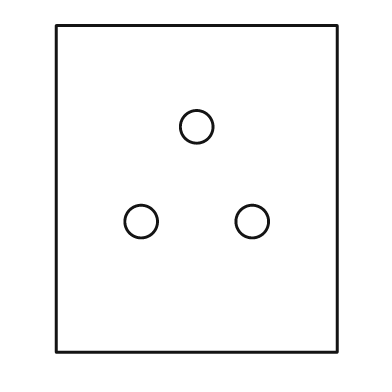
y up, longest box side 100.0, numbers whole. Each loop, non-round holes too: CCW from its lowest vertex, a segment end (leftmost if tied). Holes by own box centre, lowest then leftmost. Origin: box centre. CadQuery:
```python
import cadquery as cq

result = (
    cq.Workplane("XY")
    .moveTo(-43.0, -50.0)
    .lineTo(43.0, -50.0)
    .lineTo(43.0, 50.0)
    .lineTo(-43.0, 50.0)
    .close()
    .moveTo(-17.0, -10.0)
    .circle(5.0)
    .moveTo(17.0, -10.0)
    .circle(5.0)
    .moveTo(0.0, 19.0)
    .circle(5.0)
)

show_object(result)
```